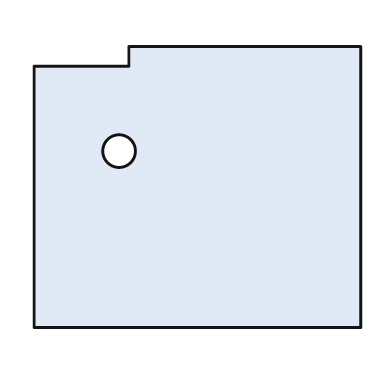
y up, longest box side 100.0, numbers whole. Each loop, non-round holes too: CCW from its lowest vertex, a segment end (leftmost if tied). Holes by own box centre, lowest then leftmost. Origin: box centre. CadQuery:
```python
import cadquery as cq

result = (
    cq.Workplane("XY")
    .moveTo(-50.0, -43.0)
    .lineTo(50.0, -43.0)
    .lineTo(50.0, 43.0)
    .lineTo(-21.0, 43.0)
    .lineTo(-21.0, 37.0)
    .lineTo(-50.0, 37.0)
    .close()
    .moveTo(-24.0, 11.0)
    .circle(5.0)
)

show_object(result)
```